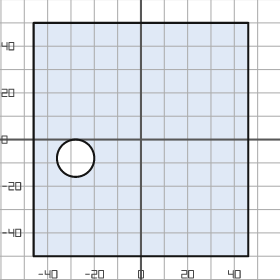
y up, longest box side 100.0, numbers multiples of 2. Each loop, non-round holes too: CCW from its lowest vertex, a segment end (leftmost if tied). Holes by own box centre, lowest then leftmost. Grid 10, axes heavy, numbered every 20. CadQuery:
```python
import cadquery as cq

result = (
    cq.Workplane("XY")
    .moveTo(-46.0, -50.0)
    .lineTo(46.0, -50.0)
    .lineTo(46.0, 50.0)
    .lineTo(-46.0, 50.0)
    .close()
    .moveTo(-28.0, -8.0)
    .circle(8.0)
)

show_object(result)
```